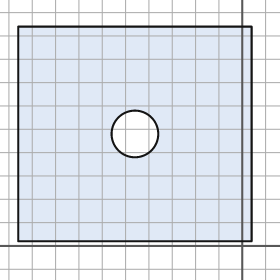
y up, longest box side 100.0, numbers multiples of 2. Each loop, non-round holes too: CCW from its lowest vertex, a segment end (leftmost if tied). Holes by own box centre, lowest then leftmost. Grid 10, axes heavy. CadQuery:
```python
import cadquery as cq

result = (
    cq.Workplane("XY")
    .moveTo(-96.0, 2.0)
    .lineTo(4.0, 2.0)
    .lineTo(4.0, 94.0)
    .lineTo(-96.0, 94.0)
    .close()
    .moveTo(-46.0, 48.0)
    .circle(10.0)
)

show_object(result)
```